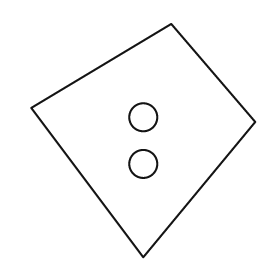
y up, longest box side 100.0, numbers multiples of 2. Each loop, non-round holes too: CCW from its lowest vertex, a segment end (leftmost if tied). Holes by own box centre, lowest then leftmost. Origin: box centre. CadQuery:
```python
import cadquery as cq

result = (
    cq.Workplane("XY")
    .moveTo(0.0, -50.0)
    .lineTo(48.0, 8.0)
    .lineTo(12.0, 50.0)
    .lineTo(-48.0, 14.0)
    .close()
    .moveTo(0.0, -10.0)
    .circle(6.0)
    .moveTo(0.0, 10.0)
    .circle(6.0)
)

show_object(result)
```